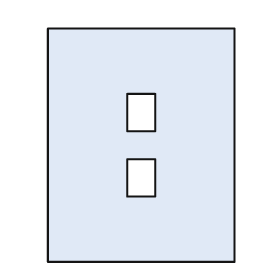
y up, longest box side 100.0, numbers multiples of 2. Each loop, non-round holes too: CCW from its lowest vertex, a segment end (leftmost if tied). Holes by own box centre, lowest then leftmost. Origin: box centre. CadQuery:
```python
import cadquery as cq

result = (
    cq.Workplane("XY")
    .moveTo(-40.0, -50.0)
    .lineTo(40.0, -50.0)
    .lineTo(40.0, 50.0)
    .lineTo(-40.0, 50.0)
    .close()
    .moveTo(-6.0, -22.0)
    .lineTo(6.0, -22.0)
    .lineTo(6.0, -6.0)
    .lineTo(-6.0, -6.0)
    .close()
    .moveTo(-6.0, 6.0)
    .lineTo(6.0, 6.0)
    .lineTo(6.0, 22.0)
    .lineTo(-6.0, 22.0)
    .close()
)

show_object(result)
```